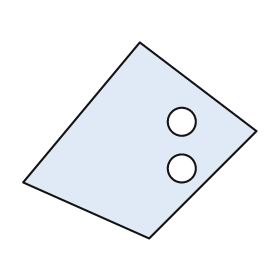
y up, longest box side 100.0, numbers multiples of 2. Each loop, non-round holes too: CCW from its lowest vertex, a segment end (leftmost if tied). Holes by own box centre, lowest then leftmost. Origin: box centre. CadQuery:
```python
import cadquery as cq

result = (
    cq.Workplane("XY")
    .moveTo(4.0, -42.0)
    .lineTo(50.0, 4.0)
    .lineTo(0.0, 42.0)
    .lineTo(-50.0, -18.0)
    .close()
    .moveTo(18.0, -12.0)
    .circle(6.0)
    .moveTo(18.0, 8.0)
    .circle(6.0)
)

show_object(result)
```